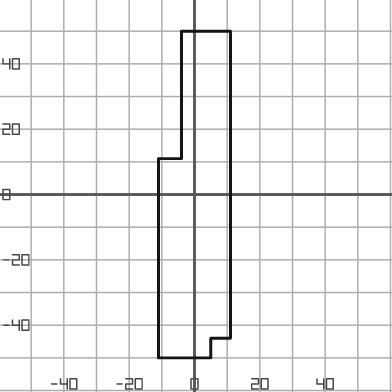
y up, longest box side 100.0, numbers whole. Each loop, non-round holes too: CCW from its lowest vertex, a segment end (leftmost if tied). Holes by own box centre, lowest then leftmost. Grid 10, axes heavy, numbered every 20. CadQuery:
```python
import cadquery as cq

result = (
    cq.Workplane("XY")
    .moveTo(-11.0, -50.0)
    .lineTo(5.0, -50.0)
    .lineTo(5.0, -44.0)
    .lineTo(11.0, -44.0)
    .lineTo(11.0, 50.0)
    .lineTo(-4.0, 50.0)
    .lineTo(-4.0, 11.0)
    .lineTo(-11.0, 11.0)
    .close()
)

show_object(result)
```